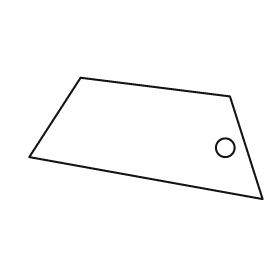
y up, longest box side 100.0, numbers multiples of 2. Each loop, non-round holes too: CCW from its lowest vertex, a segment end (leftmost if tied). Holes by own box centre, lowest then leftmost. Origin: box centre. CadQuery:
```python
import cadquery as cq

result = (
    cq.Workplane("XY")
    .moveTo(50.0, -26.0)
    .lineTo(36.0, 18.0)
    .lineTo(-28.0, 26.0)
    .lineTo(-50.0, -8.0)
    .close()
    .moveTo(34.0, -4.0)
    .circle(4.0)
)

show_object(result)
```